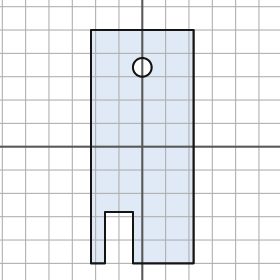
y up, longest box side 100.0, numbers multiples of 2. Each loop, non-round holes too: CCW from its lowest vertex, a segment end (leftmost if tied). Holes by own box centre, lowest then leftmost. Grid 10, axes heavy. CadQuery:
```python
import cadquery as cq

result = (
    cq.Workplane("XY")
    .moveTo(-22.0, -50.0)
    .lineTo(-16.0, -50.0)
    .lineTo(-16.0, -28.0)
    .lineTo(-4.0, -28.0)
    .lineTo(-4.0, -50.0)
    .lineTo(22.0, -50.0)
    .lineTo(22.0, 50.0)
    .lineTo(-22.0, 50.0)
    .close()
    .moveTo(0.0, 34.0)
    .circle(4.0)
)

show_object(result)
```